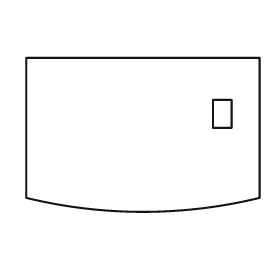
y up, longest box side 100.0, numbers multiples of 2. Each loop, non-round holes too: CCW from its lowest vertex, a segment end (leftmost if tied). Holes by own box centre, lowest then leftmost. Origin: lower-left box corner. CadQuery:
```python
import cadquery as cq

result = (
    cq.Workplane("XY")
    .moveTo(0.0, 6.0)
    .threePointArc((50.0, 0.0), (100.0, 6.0))
    .lineTo(100.0, 66.0)
    .lineTo(0.0, 66.0)
    .close()
    .moveTo(80.0, 36.0)
    .lineTo(88.0, 36.0)
    .lineTo(88.0, 48.0)
    .lineTo(80.0, 48.0)
    .close()
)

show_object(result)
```